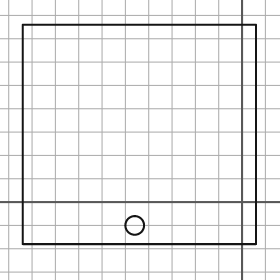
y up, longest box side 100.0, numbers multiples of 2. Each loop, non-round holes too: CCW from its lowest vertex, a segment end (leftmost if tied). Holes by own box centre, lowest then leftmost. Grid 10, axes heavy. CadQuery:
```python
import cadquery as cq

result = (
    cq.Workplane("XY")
    .moveTo(-94.0, -18.0)
    .lineTo(6.0, -18.0)
    .lineTo(6.0, 76.0)
    .lineTo(-94.0, 76.0)
    .close()
    .moveTo(-46.0, -10.0)
    .circle(4.0)
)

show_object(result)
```